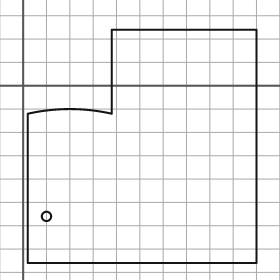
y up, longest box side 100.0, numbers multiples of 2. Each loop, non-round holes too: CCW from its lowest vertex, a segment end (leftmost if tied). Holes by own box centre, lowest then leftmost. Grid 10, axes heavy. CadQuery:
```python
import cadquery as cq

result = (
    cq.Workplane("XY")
    .moveTo(2.0, -76.0)
    .lineTo(100.0, -76.0)
    .lineTo(100.0, 24.0)
    .lineTo(38.0, 24.0)
    .lineTo(38.0, -12.0)
    .threePointArc((20.0, -10.0), (2.0, -12.0))
    .close()
    .moveTo(10.0, -56.0)
    .circle(2.0)
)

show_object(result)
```